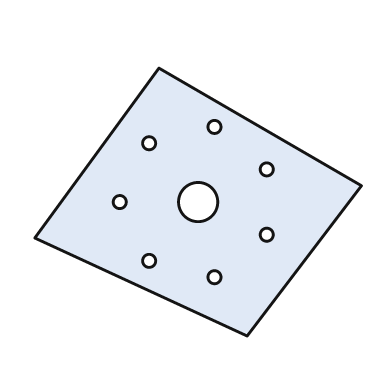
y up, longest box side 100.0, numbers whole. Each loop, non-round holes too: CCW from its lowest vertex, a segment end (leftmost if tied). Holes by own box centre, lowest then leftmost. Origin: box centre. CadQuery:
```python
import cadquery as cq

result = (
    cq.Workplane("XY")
    .moveTo(15.0, -41.0)
    .lineTo(50.0, 5.0)
    .lineTo(-12.0, 41.0)
    .lineTo(-50.0, -11.0)
    .close()
    .moveTo(5.0, -23.0)
    .circle(2.0)
    .moveTo(-15.0, -18.0)
    .circle(2.0)
    .moveTo(21.0, -10.0)
    .circle(2.0)
    .moveTo(-24.0, 0.0)
    .circle(2.0)
    .moveTo(0.0, 0.0)
    .circle(6.0)
    .moveTo(21.0, 10.0)
    .circle(2.0)
    .moveTo(-15.0, 18.0)
    .circle(2.0)
    .moveTo(5.0, 23.0)
    .circle(2.0)
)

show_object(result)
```